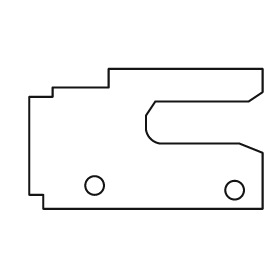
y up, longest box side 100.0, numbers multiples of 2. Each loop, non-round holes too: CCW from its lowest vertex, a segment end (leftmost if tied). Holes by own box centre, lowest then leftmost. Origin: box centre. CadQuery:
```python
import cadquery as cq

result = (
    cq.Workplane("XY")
    .moveTo(-44.0, -30.0)
    .lineTo(50.0, -30.0)
    .lineTo(50.0, -6.0)
    .lineTo(40.0, -2.0)
    .lineTo(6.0, -2.0)
    .threePointArc((2.0, 0.0), (0.0, 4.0))
    .lineTo(0.0, 10.0)
    .lineTo(4.0, 16.0)
    .lineTo(44.0, 16.0)
    .lineTo(50.0, 20.0)
    .lineTo(50.0, 30.0)
    .lineTo(-16.0, 30.0)
    .lineTo(-16.0, 22.0)
    .lineTo(-40.0, 22.0)
    .lineTo(-40.0, 18.0)
    .lineTo(-50.0, 18.0)
    .lineTo(-50.0, -24.0)
    .lineTo(-44.0, -24.0)
    .close()
    .moveTo(38.0, -22.0)
    .circle(4.0)
    .moveTo(-22.0, -20.0)
    .circle(4.0)
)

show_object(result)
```